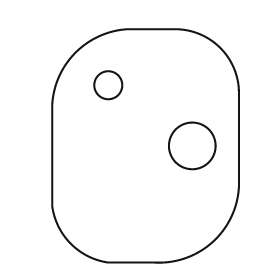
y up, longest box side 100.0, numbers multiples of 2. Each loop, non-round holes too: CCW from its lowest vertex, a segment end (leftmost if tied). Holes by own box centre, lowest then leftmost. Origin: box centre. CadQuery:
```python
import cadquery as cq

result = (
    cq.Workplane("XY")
    .moveTo(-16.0, -50.0)
    .lineTo(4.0, -50.0)
    .threePointArc((30.0, -40.0), (40.0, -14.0))
    .lineTo(40.0, 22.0)
    .threePointArc((32.0, 42.0), (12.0, 50.0))
    .lineTo(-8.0, 50.0)
    .threePointArc((-30.0, 40.0), (-40.0, 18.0))
    .lineTo(-40.0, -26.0)
    .threePointArc((-32.0, -42.0), (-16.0, -50.0))
    .close()
    .moveTo(20.0, 0.0)
    .circle(10.0)
    .moveTo(-16.0, 26.0)
    .circle(6.0)
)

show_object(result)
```